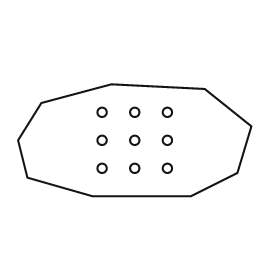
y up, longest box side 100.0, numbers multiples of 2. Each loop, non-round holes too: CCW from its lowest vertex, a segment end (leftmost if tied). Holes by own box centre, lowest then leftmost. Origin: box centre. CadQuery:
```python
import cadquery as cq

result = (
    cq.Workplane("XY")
    .moveTo(-18.0, -24.0)
    .lineTo(24.0, -24.0)
    .lineTo(44.0, -14.0)
    .lineTo(50.0, 6.0)
    .lineTo(30.0, 22.0)
    .lineTo(-10.0, 24.0)
    .lineTo(-40.0, 16.0)
    .lineTo(-50.0, 0.0)
    .lineTo(-46.0, -16.0)
    .close()
    .moveTo(-14.0, -12.0)
    .circle(2.0)
    .moveTo(0.0, -12.0)
    .circle(2.0)
    .moveTo(14.0, -12.0)
    .circle(2.0)
    .moveTo(-14.0, 0.0)
    .circle(2.0)
    .moveTo(0.0, 0.0)
    .circle(2.0)
    .moveTo(14.0, 0.0)
    .circle(2.0)
    .moveTo(-14.0, 12.0)
    .circle(2.0)
    .moveTo(0.0, 12.0)
    .circle(2.0)
    .moveTo(14.0, 12.0)
    .circle(2.0)
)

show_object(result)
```